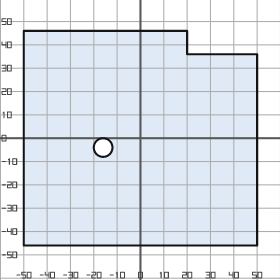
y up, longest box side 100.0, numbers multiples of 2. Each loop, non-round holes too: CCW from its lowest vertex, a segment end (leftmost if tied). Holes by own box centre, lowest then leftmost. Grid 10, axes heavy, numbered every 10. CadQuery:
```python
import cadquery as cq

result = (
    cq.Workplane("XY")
    .moveTo(-50.0, -46.0)
    .lineTo(50.0, -46.0)
    .lineTo(50.0, 36.0)
    .lineTo(20.0, 36.0)
    .lineTo(20.0, 46.0)
    .lineTo(-50.0, 46.0)
    .close()
    .moveTo(-16.0, -4.0)
    .circle(4.0)
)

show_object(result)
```